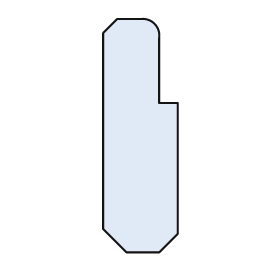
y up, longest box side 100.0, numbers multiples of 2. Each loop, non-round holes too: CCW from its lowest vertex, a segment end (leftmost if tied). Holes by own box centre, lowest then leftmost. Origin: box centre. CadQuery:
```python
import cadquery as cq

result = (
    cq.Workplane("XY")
    .moveTo(-6.0, -50.0)
    .lineTo(8.0, -50.0)
    .lineTo(16.0, -42.0)
    .lineTo(16.0, 14.0)
    .lineTo(8.0, 14.0)
    .lineTo(8.0, 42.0)
    .threePointArc((6.0, 48.0), (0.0, 50.0))
    .lineTo(-10.0, 50.0)
    .lineTo(-16.0, 44.0)
    .lineTo(-16.0, -40.0)
    .close()
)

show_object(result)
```